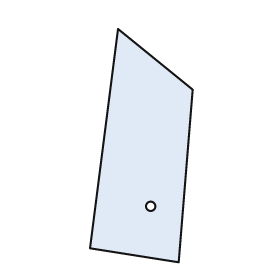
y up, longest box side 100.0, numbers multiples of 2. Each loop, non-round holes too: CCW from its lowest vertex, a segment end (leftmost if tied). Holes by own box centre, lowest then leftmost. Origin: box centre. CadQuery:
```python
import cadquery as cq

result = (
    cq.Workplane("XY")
    .moveTo(16.0, -50.0)
    .lineTo(22.0, 24.0)
    .lineTo(-10.0, 50.0)
    .lineTo(-22.0, -44.0)
    .close()
    .moveTo(4.0, -26.0)
    .circle(2.0)
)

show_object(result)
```